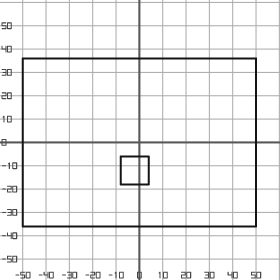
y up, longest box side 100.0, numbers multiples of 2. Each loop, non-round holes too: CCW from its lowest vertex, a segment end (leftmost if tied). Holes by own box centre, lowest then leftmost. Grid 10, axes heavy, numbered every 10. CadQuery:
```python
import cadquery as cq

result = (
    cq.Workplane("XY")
    .moveTo(-50.0, -36.0)
    .lineTo(50.0, -36.0)
    .lineTo(50.0, 36.0)
    .lineTo(-50.0, 36.0)
    .close()
    .moveTo(-8.0, -18.0)
    .lineTo(4.0, -18.0)
    .lineTo(4.0, -6.0)
    .lineTo(-8.0, -6.0)
    .close()
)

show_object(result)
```